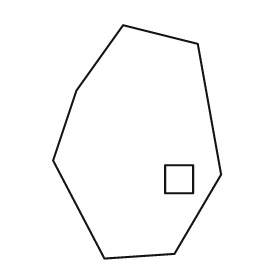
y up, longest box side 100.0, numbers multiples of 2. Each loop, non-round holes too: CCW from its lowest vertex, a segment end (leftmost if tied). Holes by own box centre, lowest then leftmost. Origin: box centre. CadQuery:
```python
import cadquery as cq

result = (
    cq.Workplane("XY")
    .moveTo(-14.0, -50.0)
    .lineTo(16.0, -48.0)
    .lineTo(36.0, -14.0)
    .lineTo(26.0, 42.0)
    .lineTo(-6.0, 50.0)
    .lineTo(-26.0, 22.0)
    .lineTo(-36.0, -8.0)
    .close()
    .moveTo(12.0, -22.0)
    .lineTo(24.0, -22.0)
    .lineTo(24.0, -10.0)
    .lineTo(12.0, -10.0)
    .close()
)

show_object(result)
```